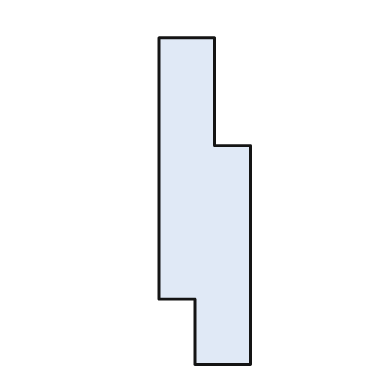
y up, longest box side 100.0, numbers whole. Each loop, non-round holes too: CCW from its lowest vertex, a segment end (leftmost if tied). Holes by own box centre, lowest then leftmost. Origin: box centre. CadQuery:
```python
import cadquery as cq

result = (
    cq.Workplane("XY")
    .moveTo(-3.0, -50.0)
    .lineTo(14.0, -50.0)
    .lineTo(14.0, 17.0)
    .lineTo(3.0, 17.0)
    .lineTo(3.0, 50.0)
    .lineTo(-14.0, 50.0)
    .lineTo(-14.0, -30.0)
    .lineTo(-3.0, -30.0)
    .close()
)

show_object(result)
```